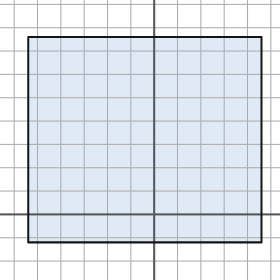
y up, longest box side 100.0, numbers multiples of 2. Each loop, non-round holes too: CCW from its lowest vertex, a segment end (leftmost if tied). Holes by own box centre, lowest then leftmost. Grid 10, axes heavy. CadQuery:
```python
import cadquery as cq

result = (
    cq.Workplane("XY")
    .moveTo(-54.0, -12.0)
    .lineTo(46.0, -12.0)
    .lineTo(46.0, 76.0)
    .lineTo(-54.0, 76.0)
    .close()
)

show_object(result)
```